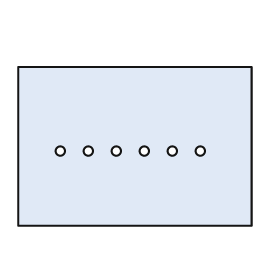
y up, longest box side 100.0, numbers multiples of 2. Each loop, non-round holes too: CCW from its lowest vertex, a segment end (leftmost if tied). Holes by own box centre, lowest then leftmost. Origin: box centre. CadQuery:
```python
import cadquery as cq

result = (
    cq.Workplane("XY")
    .moveTo(-50.0, -34.0)
    .lineTo(50.0, -34.0)
    .lineTo(50.0, 34.0)
    .lineTo(-50.0, 34.0)
    .close()
    .moveTo(-32.0, -2.0)
    .circle(2.0)
    .moveTo(-20.0, -2.0)
    .circle(2.0)
    .moveTo(-8.0, -2.0)
    .circle(2.0)
    .moveTo(4.0, -2.0)
    .circle(2.0)
    .moveTo(16.0, -2.0)
    .circle(2.0)
    .moveTo(28.0, -2.0)
    .circle(2.0)
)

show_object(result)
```